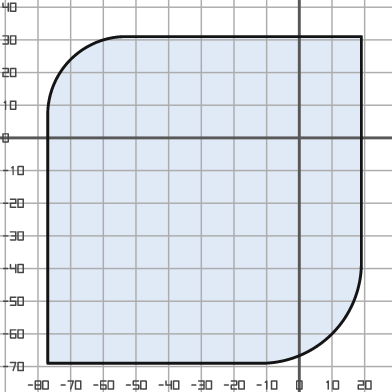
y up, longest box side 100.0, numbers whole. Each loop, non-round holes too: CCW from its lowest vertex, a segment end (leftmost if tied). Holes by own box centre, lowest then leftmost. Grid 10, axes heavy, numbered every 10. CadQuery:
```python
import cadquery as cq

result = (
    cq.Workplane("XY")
    .moveTo(-77.0, -69.0)
    .lineTo(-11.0, -69.0)
    .threePointArc((10.0, -60.0), (19.0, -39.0))
    .lineTo(19.0, 31.0)
    .lineTo(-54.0, 31.0)
    .threePointArc((-70.0, 24.0), (-77.0, 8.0))
    .close()
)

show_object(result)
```